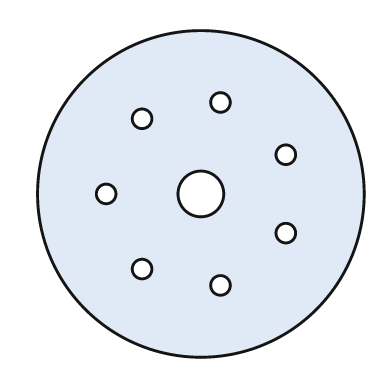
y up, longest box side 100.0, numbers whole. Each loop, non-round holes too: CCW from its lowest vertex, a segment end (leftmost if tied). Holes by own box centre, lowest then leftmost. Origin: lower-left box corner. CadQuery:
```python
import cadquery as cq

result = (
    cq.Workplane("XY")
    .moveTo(50.0, 50.0)
    .circle(50.0)
    .moveTo(56.0, 22.0)
    .circle(3.0)
    .moveTo(32.0, 27.0)
    .circle(3.0)
    .moveTo(76.0, 38.0)
    .circle(3.0)
    .moveTo(21.0, 50.0)
    .circle(3.0)
    .moveTo(50.0, 50.0)
    .circle(7.0)
    .moveTo(76.0, 62.0)
    .circle(3.0)
    .moveTo(32.0, 73.0)
    .circle(3.0)
    .moveTo(56.0, 78.0)
    .circle(3.0)
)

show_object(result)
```